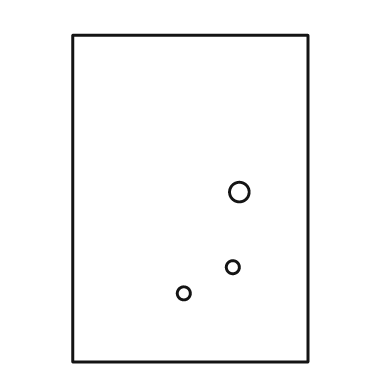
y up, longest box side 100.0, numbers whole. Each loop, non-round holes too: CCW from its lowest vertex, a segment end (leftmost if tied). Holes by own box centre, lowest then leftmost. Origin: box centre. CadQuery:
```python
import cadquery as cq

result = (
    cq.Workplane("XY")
    .moveTo(-36.0, -50.0)
    .lineTo(36.0, -50.0)
    .lineTo(36.0, 50.0)
    .lineTo(-36.0, 50.0)
    .close()
    .moveTo(-2.0, -29.0)
    .circle(2.0)
    .moveTo(13.0, -21.0)
    .circle(2.0)
    .moveTo(15.0, 2.0)
    .circle(3.0)
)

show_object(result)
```